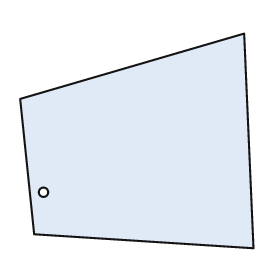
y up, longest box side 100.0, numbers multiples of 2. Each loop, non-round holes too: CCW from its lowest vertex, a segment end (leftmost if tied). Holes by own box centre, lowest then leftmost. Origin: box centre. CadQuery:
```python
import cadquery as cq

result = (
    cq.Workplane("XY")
    .moveTo(50.0, -46.0)
    .lineTo(46.0, 46.0)
    .lineTo(-50.0, 18.0)
    .lineTo(-44.0, -40.0)
    .close()
    .moveTo(-40.0, -22.0)
    .circle(2.0)
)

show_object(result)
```